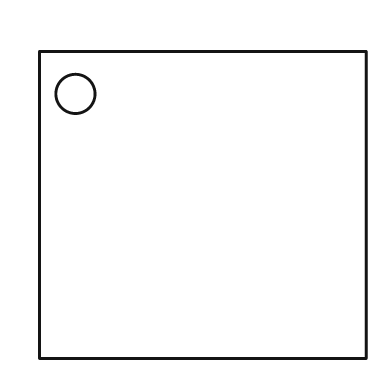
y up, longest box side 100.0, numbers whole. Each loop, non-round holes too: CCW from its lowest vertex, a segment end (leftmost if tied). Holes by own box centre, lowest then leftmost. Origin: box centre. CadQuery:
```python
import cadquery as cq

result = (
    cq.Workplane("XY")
    .moveTo(-50.0, -47.0)
    .lineTo(50.0, -47.0)
    .lineTo(50.0, 47.0)
    .lineTo(-50.0, 47.0)
    .close()
    .moveTo(-39.0, 34.0)
    .circle(6.0)
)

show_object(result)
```